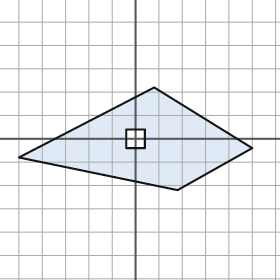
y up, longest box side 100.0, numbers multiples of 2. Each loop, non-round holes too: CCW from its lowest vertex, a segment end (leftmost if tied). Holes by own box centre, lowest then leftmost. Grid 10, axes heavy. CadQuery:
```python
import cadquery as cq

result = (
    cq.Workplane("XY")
    .moveTo(18.0, -22.0)
    .lineTo(50.0, -4.0)
    .lineTo(8.0, 22.0)
    .lineTo(-50.0, -8.0)
    .close()
    .moveTo(-4.0, -4.0)
    .lineTo(4.0, -4.0)
    .lineTo(4.0, 4.0)
    .lineTo(-4.0, 4.0)
    .close()
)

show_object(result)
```